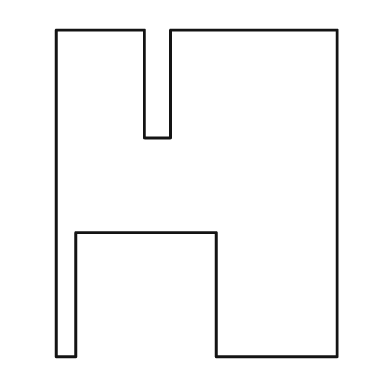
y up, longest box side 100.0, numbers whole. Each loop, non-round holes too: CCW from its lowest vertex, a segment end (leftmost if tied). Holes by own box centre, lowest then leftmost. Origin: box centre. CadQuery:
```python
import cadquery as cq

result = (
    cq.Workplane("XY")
    .moveTo(-43.0, -50.0)
    .lineTo(-37.0, -50.0)
    .lineTo(-37.0, -12.0)
    .lineTo(6.0, -12.0)
    .lineTo(6.0, -50.0)
    .lineTo(43.0, -50.0)
    .lineTo(43.0, 50.0)
    .lineTo(-8.0, 50.0)
    .lineTo(-8.0, 17.0)
    .lineTo(-16.0, 17.0)
    .lineTo(-16.0, 50.0)
    .lineTo(-43.0, 50.0)
    .close()
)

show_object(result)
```